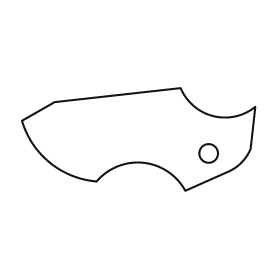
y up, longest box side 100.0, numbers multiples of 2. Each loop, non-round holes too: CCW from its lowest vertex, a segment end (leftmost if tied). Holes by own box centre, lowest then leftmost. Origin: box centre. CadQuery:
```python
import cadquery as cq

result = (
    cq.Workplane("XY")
    .moveTo(20.0, -22.0)
    .lineTo(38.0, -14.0)
    .threePointArc((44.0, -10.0), (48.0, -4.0))
    .lineTo(50.0, 14.0)
    .threePointArc((32.0, 10.0), (18.0, 22.0))
    .lineTo(-36.0, 16.0)
    .lineTo(-50.0, 8.0)
    .threePointArc((-38.0, -10.0), (-18.0, -18.0))
    .threePointArc((2.0, -10.0), (20.0, -22.0))
    .close()
    .moveTo(30.0, -6.0)
    .circle(4.0)
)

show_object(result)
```